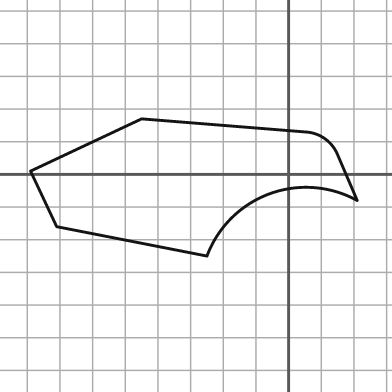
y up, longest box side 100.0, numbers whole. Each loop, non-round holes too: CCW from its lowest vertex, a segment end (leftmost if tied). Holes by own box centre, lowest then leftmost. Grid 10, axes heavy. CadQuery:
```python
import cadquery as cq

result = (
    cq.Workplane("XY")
    .moveTo(-25.0, -25.0)
    .threePointArc((-6.0, -6.0), (21.0, -8.0))
    .lineTo(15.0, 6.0)
    .threePointArc((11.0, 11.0), (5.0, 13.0))
    .lineTo(-45.0, 17.0)
    .lineTo(-79.0, 1.0)
    .lineTo(-71.0, -16.0)
    .close()
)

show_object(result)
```